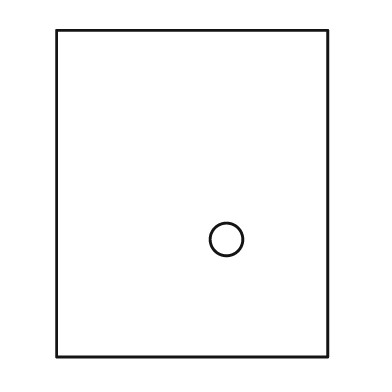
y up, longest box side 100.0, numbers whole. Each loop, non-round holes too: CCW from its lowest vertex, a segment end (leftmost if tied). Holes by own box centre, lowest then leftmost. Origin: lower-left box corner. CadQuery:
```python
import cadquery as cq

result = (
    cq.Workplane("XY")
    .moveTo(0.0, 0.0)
    .lineTo(83.0, 0.0)
    .lineTo(83.0, 100.0)
    .lineTo(0.0, 100.0)
    .close()
    .moveTo(52.0, 36.0)
    .circle(5.0)
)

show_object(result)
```